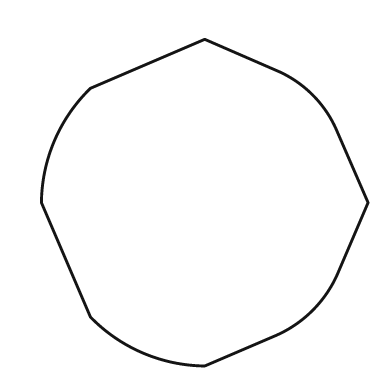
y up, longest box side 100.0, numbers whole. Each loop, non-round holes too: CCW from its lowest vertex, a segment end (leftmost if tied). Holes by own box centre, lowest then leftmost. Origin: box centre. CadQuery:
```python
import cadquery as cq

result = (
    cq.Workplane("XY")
    .moveTo(0.0, -50.0)
    .lineTo(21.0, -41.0)
    .threePointArc((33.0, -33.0), (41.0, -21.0))
    .lineTo(50.0, 0.0)
    .lineTo(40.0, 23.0)
    .threePointArc((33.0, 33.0), (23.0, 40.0))
    .lineTo(0.0, 50.0)
    .lineTo(-35.0, 35.0)
    .threePointArc((-46.0, 19.0), (-50.0, 0.0))
    .lineTo(-35.0, -35.0)
    .threePointArc((-19.0, -46.0), (0.0, -50.0))
    .close()
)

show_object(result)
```